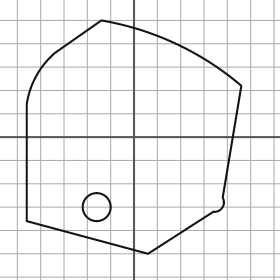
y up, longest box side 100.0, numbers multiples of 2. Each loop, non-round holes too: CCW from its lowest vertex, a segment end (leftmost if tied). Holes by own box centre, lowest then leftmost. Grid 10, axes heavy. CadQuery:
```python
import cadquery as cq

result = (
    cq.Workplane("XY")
    .moveTo(6.0, -50.0)
    .lineTo(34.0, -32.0)
    .threePointArc((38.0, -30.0), (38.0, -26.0))
    .lineTo(46.0, 22.0)
    .threePointArc((18.0, 40.0), (-14.0, 50.0))
    .lineTo(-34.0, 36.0)
    .threePointArc((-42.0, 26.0), (-46.0, 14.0))
    .lineTo(-46.0, -36.0)
    .close()
    .moveTo(-16.0, -30.0)
    .circle(6.0)
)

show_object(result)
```